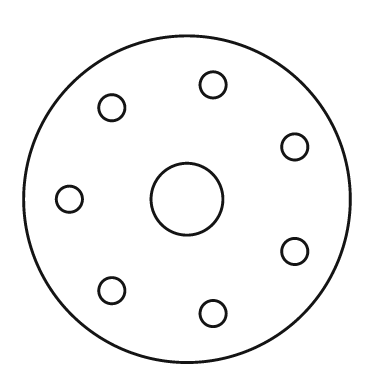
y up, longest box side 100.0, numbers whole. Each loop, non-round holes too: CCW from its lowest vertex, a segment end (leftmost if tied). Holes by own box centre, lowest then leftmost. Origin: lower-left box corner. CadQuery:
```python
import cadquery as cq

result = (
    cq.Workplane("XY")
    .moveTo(50.0, 50.0)
    .circle(50.0)
    .moveTo(58.0, 15.0)
    .circle(4.0)
    .moveTo(27.0, 22.0)
    .circle(4.0)
    .moveTo(83.0, 34.0)
    .circle(4.0)
    .moveTo(14.0, 50.0)
    .circle(4.0)
    .moveTo(50.0, 50.0)
    .circle(11.0)
    .moveTo(83.0, 66.0)
    .circle(4.0)
    .moveTo(27.0, 78.0)
    .circle(4.0)
    .moveTo(58.0, 85.0)
    .circle(4.0)
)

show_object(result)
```